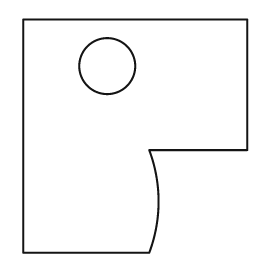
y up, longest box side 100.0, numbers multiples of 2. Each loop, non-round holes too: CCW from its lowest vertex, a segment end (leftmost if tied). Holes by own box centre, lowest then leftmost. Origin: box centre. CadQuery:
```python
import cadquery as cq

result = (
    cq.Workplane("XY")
    .moveTo(-48.0, -50.0)
    .lineTo(6.0, -50.0)
    .threePointArc((10.0, -28.0), (6.0, -6.0))
    .lineTo(48.0, -6.0)
    .lineTo(48.0, 50.0)
    .lineTo(-48.0, 50.0)
    .close()
    .moveTo(-12.0, 30.0)
    .circle(12.0)
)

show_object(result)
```